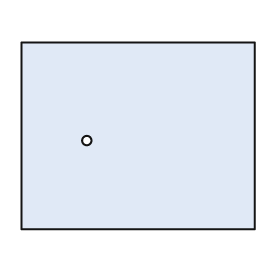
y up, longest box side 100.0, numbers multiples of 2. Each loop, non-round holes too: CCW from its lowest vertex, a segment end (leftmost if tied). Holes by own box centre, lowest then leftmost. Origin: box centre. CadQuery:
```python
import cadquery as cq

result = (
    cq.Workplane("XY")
    .moveTo(-50.0, -40.0)
    .lineTo(50.0, -40.0)
    .lineTo(50.0, 40.0)
    .lineTo(-50.0, 40.0)
    .close()
    .moveTo(-22.0, -2.0)
    .circle(2.0)
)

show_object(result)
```